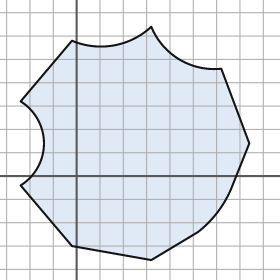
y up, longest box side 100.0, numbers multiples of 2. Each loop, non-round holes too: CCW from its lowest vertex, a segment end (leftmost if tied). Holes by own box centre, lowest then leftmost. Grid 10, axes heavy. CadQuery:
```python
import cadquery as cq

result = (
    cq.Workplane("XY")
    .moveTo(32.0, -36.0)
    .lineTo(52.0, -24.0)
    .threePointArc((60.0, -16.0), (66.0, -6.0))
    .lineTo(74.0, 14.0)
    .lineTo(62.0, 46.0)
    .threePointArc((44.0, 50.0), (32.0, 64.0))
    .threePointArc((16.0, 56.0), (-2.0, 58.0))
    .lineTo(-24.0, 32.0)
    .threePointArc((-14.0, 14.0), (-24.0, -4.0))
    .lineTo(-2.0, -30.0)
    .close()
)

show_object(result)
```